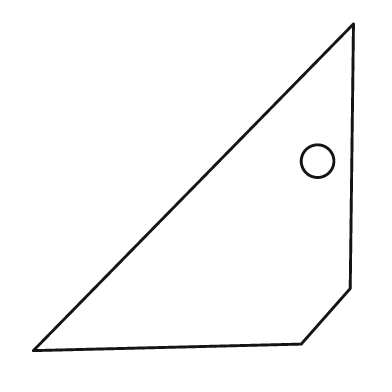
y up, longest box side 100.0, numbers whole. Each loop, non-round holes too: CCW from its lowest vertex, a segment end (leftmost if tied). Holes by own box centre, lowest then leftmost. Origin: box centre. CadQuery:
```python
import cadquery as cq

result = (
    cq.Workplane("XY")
    .moveTo(-49.0, -50.0)
    .lineTo(33.0, -48.0)
    .lineTo(48.0, -31.0)
    .lineTo(49.0, 50.0)
    .close()
    .moveTo(38.0, 8.0)
    .circle(5.0)
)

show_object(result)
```